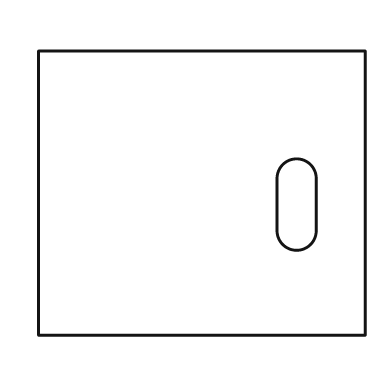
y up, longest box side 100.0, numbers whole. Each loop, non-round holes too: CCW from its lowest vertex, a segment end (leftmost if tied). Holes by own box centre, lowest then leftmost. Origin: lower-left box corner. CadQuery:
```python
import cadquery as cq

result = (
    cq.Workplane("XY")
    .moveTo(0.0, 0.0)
    .lineTo(100.0, 0.0)
    .lineTo(100.0, 87.0)
    .lineTo(0.0, 87.0)
    .close()
    .moveTo(73.0, 32.0)
    .threePointArc((79.0, 26.0), (85.0, 32.0))
    .lineTo(85.0, 48.0)
    .threePointArc((79.0, 54.0), (73.0, 48.0))
    .close()
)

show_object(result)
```